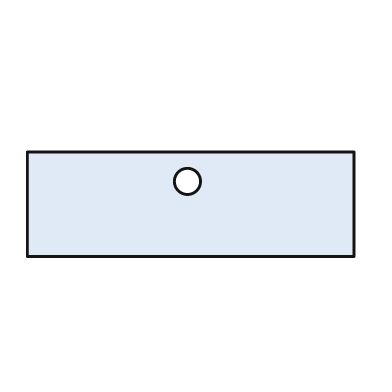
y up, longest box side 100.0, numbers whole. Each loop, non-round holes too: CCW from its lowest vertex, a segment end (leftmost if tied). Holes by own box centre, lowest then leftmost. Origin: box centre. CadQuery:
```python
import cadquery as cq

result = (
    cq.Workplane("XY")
    .moveTo(-50.0, -16.0)
    .lineTo(50.0, -16.0)
    .lineTo(50.0, 16.0)
    .lineTo(-50.0, 16.0)
    .close()
    .moveTo(-1.0, 7.0)
    .circle(4.0)
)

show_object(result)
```